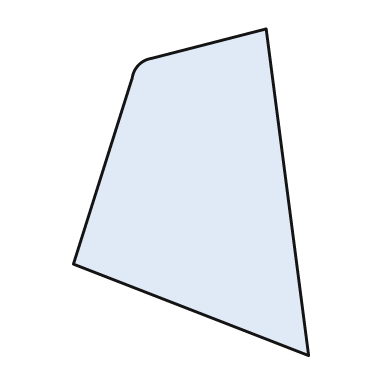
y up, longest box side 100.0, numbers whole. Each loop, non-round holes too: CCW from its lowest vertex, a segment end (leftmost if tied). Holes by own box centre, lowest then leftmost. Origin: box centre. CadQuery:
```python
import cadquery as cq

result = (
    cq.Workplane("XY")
    .moveTo(36.0, -50.0)
    .lineTo(23.0, 50.0)
    .lineTo(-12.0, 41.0)
    .threePointArc((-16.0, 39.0), (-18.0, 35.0))
    .lineTo(-36.0, -22.0)
    .close()
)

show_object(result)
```